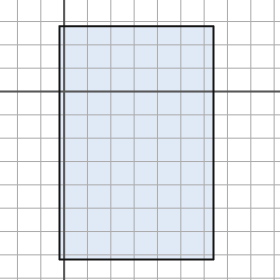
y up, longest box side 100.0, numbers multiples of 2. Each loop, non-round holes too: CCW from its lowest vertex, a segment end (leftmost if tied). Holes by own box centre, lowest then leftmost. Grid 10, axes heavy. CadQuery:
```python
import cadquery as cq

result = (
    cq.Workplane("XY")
    .moveTo(-2.0, -72.0)
    .lineTo(64.0, -72.0)
    .lineTo(64.0, 28.0)
    .lineTo(-2.0, 28.0)
    .close()
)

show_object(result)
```